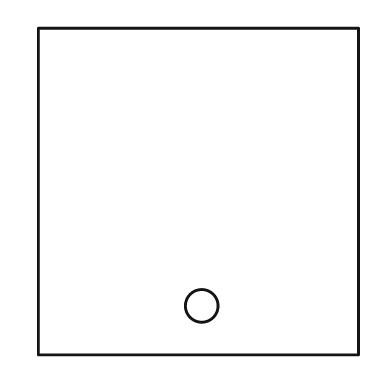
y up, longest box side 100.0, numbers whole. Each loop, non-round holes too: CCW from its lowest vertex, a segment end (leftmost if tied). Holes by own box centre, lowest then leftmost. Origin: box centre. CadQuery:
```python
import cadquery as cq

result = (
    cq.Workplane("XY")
    .moveTo(-49.0, -50.0)
    .lineTo(49.0, -50.0)
    .lineTo(49.0, 50.0)
    .lineTo(-49.0, 50.0)
    .close()
    .moveTo(1.0, -35.0)
    .circle(5.0)
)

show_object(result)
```